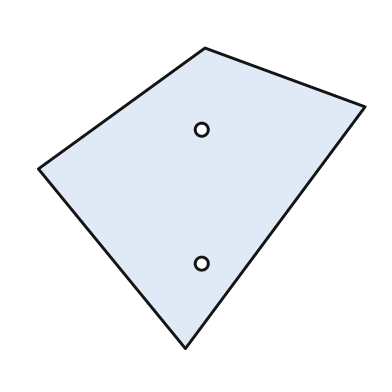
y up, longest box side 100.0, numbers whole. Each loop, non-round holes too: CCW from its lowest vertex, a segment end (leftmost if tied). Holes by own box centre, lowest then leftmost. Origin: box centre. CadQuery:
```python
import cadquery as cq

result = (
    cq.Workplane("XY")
    .moveTo(-5.0, -46.0)
    .lineTo(50.0, 28.0)
    .lineTo(1.0, 46.0)
    .lineTo(-50.0, 9.0)
    .close()
    .moveTo(0.0, -20.0)
    .circle(2.0)
    .moveTo(0.0, 21.0)
    .circle(2.0)
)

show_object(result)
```